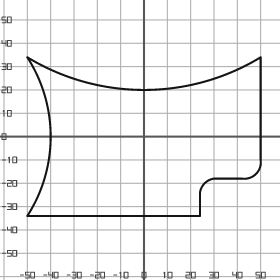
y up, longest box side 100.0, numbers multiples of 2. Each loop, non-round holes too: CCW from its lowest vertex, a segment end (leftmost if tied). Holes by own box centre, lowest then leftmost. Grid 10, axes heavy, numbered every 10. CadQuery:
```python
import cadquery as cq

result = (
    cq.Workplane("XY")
    .moveTo(-50.0, -34.0)
    .lineTo(24.0, -34.0)
    .lineTo(24.0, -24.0)
    .threePointArc((26.0, -20.0), (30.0, -18.0))
    .lineTo(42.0, -18.0)
    .threePointArc((48.0, -16.0), (50.0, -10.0))
    .lineTo(50.0, 34.0)
    .threePointArc((0.0, 20.0), (-50.0, 34.0))
    .threePointArc((-40.0, 0.0), (-50.0, -34.0))
    .close()
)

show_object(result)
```